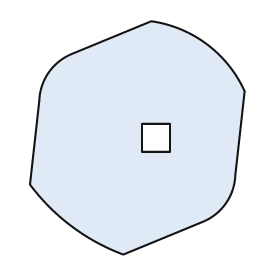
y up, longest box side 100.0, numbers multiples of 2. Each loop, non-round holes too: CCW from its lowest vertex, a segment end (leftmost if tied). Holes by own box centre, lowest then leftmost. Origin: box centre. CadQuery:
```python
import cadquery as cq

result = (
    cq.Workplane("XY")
    .moveTo(-6.0, -50.0)
    .lineTo(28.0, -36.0)
    .threePointArc((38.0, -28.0), (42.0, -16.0))
    .lineTo(46.0, 20.0)
    .threePointArc((30.0, 40.0), (6.0, 50.0))
    .lineTo(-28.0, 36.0)
    .threePointArc((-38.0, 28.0), (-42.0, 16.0))
    .lineTo(-46.0, -20.0)
    .threePointArc((-28.0, -38.0), (-6.0, -50.0))
    .close()
    .moveTo(2.0, -6.0)
    .lineTo(14.0, -6.0)
    .lineTo(14.0, 6.0)
    .lineTo(2.0, 6.0)
    .close()
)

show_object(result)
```